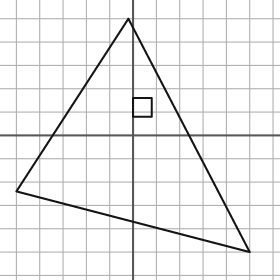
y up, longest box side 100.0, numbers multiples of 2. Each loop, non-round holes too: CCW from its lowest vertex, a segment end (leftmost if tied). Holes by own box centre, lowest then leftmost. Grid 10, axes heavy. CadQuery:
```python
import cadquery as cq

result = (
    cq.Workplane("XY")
    .moveTo(50.0, -50.0)
    .lineTo(-2.0, 50.0)
    .lineTo(-50.0, -24.0)
    .close()
    .moveTo(0.0, 8.0)
    .lineTo(8.0, 8.0)
    .lineTo(8.0, 16.0)
    .lineTo(0.0, 16.0)
    .close()
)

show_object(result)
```